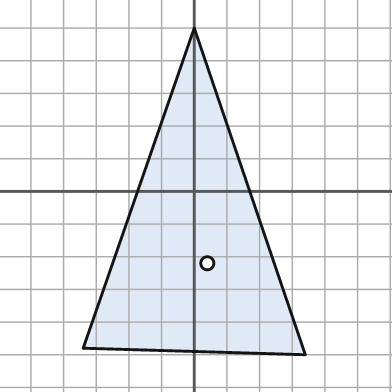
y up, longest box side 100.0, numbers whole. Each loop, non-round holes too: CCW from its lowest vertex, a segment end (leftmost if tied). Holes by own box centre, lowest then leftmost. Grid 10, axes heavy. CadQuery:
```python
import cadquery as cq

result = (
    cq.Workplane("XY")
    .moveTo(34.0, -50.0)
    .lineTo(0.0, 50.0)
    .lineTo(-34.0, -48.0)
    .close()
    .moveTo(4.0, -22.0)
    .circle(2.0)
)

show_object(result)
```